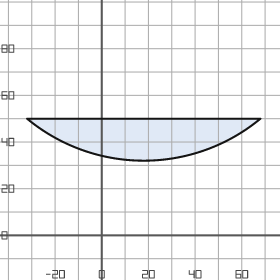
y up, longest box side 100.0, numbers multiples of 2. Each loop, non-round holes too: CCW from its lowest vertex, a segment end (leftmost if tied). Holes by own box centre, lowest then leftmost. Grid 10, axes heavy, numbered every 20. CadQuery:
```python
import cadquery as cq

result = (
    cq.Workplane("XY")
    .moveTo(-32.0, 50.0)
    .threePointArc((18.0, 32.0), (68.0, 50.0))
    .close()
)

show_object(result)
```